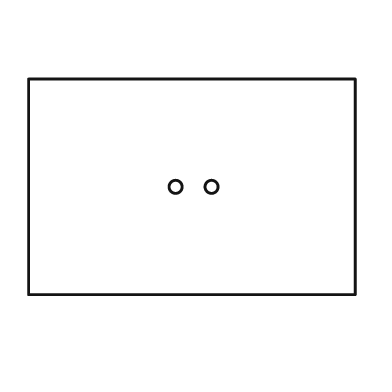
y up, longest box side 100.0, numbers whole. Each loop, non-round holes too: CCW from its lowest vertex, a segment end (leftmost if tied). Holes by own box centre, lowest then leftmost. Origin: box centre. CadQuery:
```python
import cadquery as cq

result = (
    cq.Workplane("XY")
    .moveTo(-50.0, -33.0)
    .lineTo(50.0, -33.0)
    .lineTo(50.0, 33.0)
    .lineTo(-50.0, 33.0)
    .close()
    .moveTo(-5.0, 0.0)
    .circle(2.0)
    .moveTo(6.0, 0.0)
    .circle(2.0)
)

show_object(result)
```